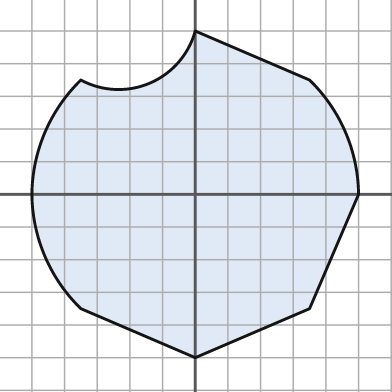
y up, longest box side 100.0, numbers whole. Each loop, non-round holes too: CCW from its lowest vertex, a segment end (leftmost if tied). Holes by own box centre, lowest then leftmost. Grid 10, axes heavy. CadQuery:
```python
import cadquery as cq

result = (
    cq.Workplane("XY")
    .moveTo(0.0, -50.0)
    .lineTo(35.0, -35.0)
    .lineTo(50.0, 0.0)
    .threePointArc((46.0, 19.0), (35.0, 35.0))
    .lineTo(0.0, 50.0)
    .threePointArc((-14.0, 34.0), (-35.0, 35.0))
    .threePointArc((-46.0, 19.0), (-50.0, 0.0))
    .threePointArc((-46.0, -19.0), (-35.0, -35.0))
    .close()
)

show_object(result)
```